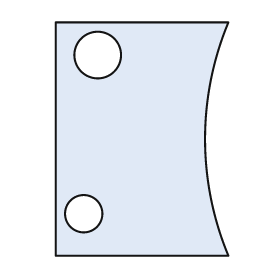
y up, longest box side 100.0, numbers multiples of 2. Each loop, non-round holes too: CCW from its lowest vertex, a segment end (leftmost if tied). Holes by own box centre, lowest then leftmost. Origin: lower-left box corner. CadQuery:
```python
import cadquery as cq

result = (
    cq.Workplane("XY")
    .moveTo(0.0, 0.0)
    .lineTo(74.0, 0.0)
    .threePointArc((64.0, 50.0), (74.0, 100.0))
    .lineTo(0.0, 100.0)
    .close()
    .moveTo(12.0, 18.0)
    .circle(8.0)
    .moveTo(18.0, 86.0)
    .circle(10.0)
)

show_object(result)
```